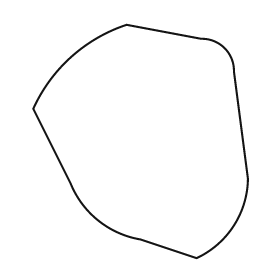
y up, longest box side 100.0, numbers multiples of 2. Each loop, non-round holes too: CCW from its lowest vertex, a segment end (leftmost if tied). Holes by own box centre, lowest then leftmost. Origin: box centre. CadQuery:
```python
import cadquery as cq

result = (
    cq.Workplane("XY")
    .moveTo(24.0, -50.0)
    .threePointArc((40.0, -36.0), (46.0, -16.0))
    .lineTo(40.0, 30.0)
    .threePointArc((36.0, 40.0), (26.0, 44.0))
    .lineTo(-6.0, 50.0)
    .threePointArc((-30.0, 36.0), (-46.0, 14.0))
    .lineTo(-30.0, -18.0)
    .threePointArc((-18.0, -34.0), (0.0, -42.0))
    .close()
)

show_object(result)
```